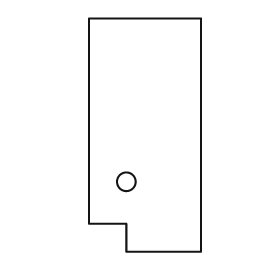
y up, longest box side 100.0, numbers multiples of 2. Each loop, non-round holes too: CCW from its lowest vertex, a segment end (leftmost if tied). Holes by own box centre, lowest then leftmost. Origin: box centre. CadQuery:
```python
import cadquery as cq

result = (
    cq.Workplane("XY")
    .moveTo(-8.0, -50.0)
    .lineTo(24.0, -50.0)
    .lineTo(24.0, 50.0)
    .lineTo(-24.0, 50.0)
    .lineTo(-24.0, -38.0)
    .lineTo(-8.0, -38.0)
    .close()
    .moveTo(-8.0, -20.0)
    .circle(4.0)
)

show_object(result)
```